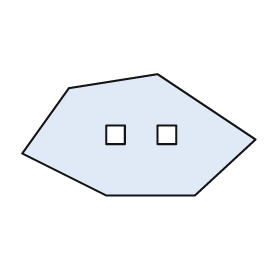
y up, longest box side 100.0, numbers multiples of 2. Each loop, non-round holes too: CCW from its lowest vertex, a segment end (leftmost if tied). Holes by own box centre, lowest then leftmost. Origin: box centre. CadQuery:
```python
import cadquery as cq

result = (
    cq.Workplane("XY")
    .moveTo(-14.0, -26.0)
    .lineTo(24.0, -26.0)
    .lineTo(50.0, -2.0)
    .lineTo(8.0, 26.0)
    .lineTo(-30.0, 20.0)
    .lineTo(-50.0, -8.0)
    .close()
    .moveTo(-14.0, -4.0)
    .lineTo(-6.0, -4.0)
    .lineTo(-6.0, 4.0)
    .lineTo(-14.0, 4.0)
    .close()
    .moveTo(8.0, -4.0)
    .lineTo(16.0, -4.0)
    .lineTo(16.0, 4.0)
    .lineTo(8.0, 4.0)
    .close()
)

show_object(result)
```